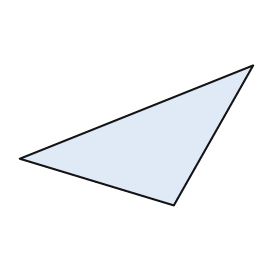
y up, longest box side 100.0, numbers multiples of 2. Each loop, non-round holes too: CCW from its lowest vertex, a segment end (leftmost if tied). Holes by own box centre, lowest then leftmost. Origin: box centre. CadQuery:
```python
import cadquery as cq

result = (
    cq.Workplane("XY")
    .moveTo(16.0, -30.0)
    .lineTo(50.0, 30.0)
    .lineTo(-50.0, -10.0)
    .close()
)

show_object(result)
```